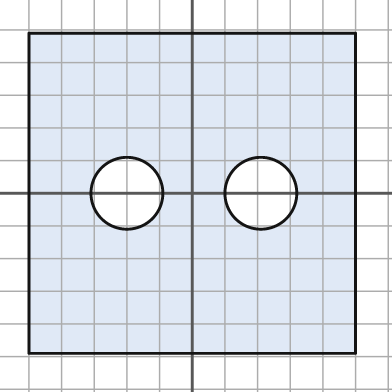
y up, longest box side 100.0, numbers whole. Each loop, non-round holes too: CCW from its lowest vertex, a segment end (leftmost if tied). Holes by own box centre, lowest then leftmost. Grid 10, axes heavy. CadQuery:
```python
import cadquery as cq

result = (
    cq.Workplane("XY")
    .moveTo(-50.0, -49.0)
    .lineTo(50.0, -49.0)
    .lineTo(50.0, 49.0)
    .lineTo(-50.0, 49.0)
    .close()
    .moveTo(-20.0, 0.0)
    .circle(11.0)
    .moveTo(21.0, 0.0)
    .circle(11.0)
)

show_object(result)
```